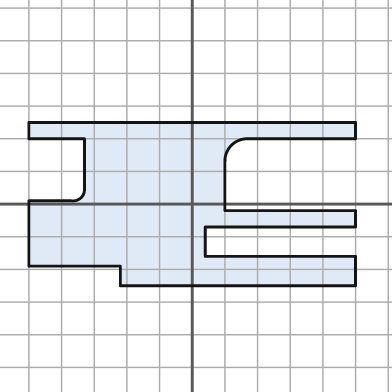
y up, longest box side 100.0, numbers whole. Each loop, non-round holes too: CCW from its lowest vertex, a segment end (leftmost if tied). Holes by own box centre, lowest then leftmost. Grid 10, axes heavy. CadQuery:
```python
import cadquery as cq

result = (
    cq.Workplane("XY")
    .moveTo(-22.0, -25.0)
    .lineTo(50.0, -25.0)
    .lineTo(50.0, -16.0)
    .lineTo(4.0, -16.0)
    .lineTo(4.0, -7.0)
    .lineTo(50.0, -7.0)
    .lineTo(50.0, -2.0)
    .lineTo(10.0, -2.0)
    .lineTo(10.0, 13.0)
    .threePointArc((12.0, 18.0), (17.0, 20.0))
    .lineTo(50.0, 20.0)
    .lineTo(50.0, 25.0)
    .lineTo(-50.0, 25.0)
    .lineTo(-50.0, 20.0)
    .lineTo(-33.0, 20.0)
    .lineTo(-33.0, 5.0)
    .threePointArc((-34.0, 2.0), (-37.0, 1.0))
    .lineTo(-50.0, 1.0)
    .lineTo(-50.0, -19.0)
    .lineTo(-22.0, -19.0)
    .close()
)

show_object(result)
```